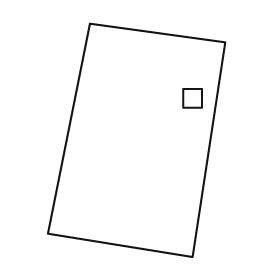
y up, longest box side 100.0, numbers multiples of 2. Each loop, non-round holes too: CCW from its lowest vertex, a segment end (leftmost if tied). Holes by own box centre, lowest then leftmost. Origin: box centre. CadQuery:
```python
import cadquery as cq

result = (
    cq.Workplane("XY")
    .moveTo(24.0, -50.0)
    .lineTo(38.0, 42.0)
    .lineTo(-20.0, 50.0)
    .lineTo(-38.0, -40.0)
    .close()
    .moveTo(20.0, 14.0)
    .lineTo(28.0, 14.0)
    .lineTo(28.0, 22.0)
    .lineTo(20.0, 22.0)
    .close()
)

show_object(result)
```